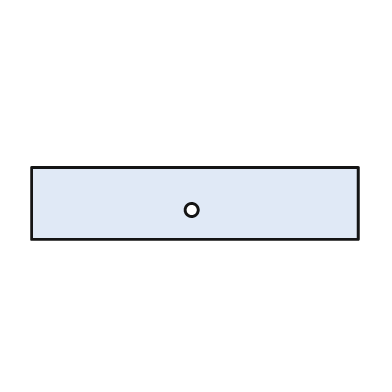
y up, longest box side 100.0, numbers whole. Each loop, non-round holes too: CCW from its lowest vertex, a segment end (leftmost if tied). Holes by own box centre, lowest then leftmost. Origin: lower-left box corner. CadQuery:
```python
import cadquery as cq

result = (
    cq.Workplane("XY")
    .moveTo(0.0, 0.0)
    .lineTo(100.0, 0.0)
    .lineTo(100.0, 22.0)
    .lineTo(0.0, 22.0)
    .close()
    .moveTo(49.0, 9.0)
    .circle(2.0)
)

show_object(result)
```